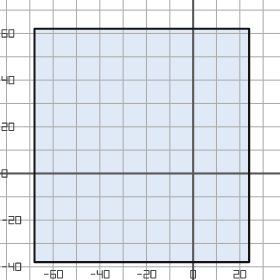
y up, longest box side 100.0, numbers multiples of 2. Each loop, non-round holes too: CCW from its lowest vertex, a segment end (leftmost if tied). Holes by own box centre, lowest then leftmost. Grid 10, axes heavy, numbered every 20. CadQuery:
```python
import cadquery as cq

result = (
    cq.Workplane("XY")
    .moveTo(-68.0, -38.0)
    .lineTo(24.0, -38.0)
    .lineTo(24.0, 62.0)
    .lineTo(-68.0, 62.0)
    .close()
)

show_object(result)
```